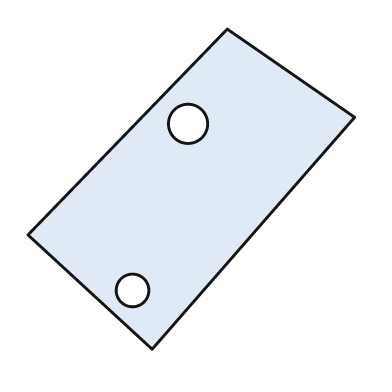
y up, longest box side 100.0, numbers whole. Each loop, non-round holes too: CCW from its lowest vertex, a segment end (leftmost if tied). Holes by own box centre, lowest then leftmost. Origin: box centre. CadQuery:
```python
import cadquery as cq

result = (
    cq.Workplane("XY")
    .moveTo(-12.0, -49.0)
    .lineTo(50.0, 22.0)
    .lineTo(11.0, 49.0)
    .lineTo(-50.0, -14.0)
    .close()
    .moveTo(-18.0, -31.0)
    .circle(5.0)
    .moveTo(-1.0, 20.0)
    .circle(6.0)
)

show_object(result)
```